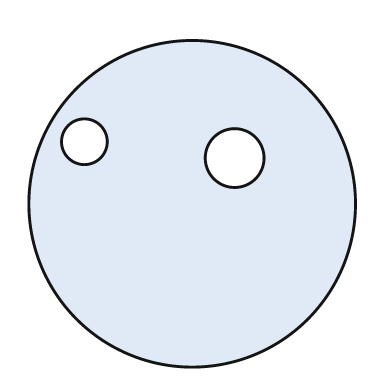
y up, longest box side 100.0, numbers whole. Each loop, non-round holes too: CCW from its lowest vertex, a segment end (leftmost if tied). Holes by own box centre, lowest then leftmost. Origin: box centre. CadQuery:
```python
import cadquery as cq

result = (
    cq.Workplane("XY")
    .moveTo(0.0, 0.0)
    .circle(50.0)
    .moveTo(13.0, 14.0)
    .circle(9.0)
    .moveTo(-33.0, 19.0)
    .circle(7.0)
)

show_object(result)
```